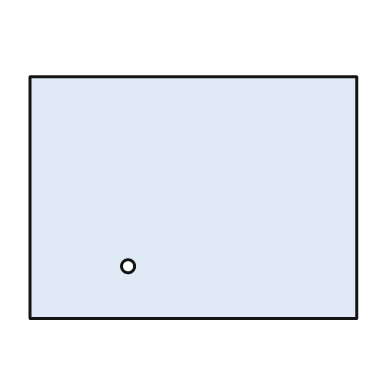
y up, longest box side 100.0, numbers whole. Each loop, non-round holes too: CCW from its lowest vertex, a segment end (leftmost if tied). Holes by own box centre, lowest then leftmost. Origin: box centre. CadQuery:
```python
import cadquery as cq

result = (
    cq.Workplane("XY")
    .moveTo(-50.0, -37.0)
    .lineTo(50.0, -37.0)
    .lineTo(50.0, 37.0)
    .lineTo(-50.0, 37.0)
    .close()
    .moveTo(-20.0, -21.0)
    .circle(2.0)
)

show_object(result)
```